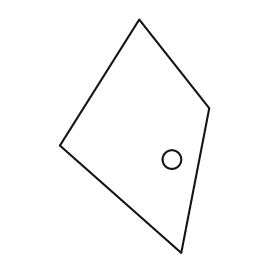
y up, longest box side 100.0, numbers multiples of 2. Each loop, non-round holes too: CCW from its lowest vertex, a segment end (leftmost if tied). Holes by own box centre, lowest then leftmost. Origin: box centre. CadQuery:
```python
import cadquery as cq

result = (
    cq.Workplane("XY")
    .moveTo(20.0, -50.0)
    .lineTo(32.0, 12.0)
    .lineTo(2.0, 50.0)
    .lineTo(-32.0, -4.0)
    .close()
    .moveTo(16.0, -10.0)
    .circle(4.0)
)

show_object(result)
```